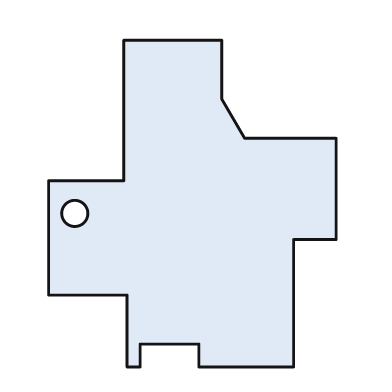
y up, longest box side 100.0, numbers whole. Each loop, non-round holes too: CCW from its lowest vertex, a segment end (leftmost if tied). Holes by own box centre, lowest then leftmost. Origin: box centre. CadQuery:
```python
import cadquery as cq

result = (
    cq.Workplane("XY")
    .moveTo(-20.0, -50.0)
    .lineTo(-16.0, -50.0)
    .lineTo(-16.0, -43.0)
    .lineTo(2.0, -43.0)
    .lineTo(2.0, -50.0)
    .lineTo(31.0, -50.0)
    .lineTo(31.0, -11.0)
    .lineTo(44.0, -11.0)
    .lineTo(44.0, 20.0)
    .lineTo(16.0, 20.0)
    .lineTo(9.0, 32.0)
    .lineTo(9.0, 50.0)
    .lineTo(-21.0, 50.0)
    .lineTo(-21.0, 7.0)
    .lineTo(-44.0, 7.0)
    .lineTo(-44.0, -28.0)
    .lineTo(-20.0, -28.0)
    .close()
    .moveTo(-36.0, -3.0)
    .circle(4.0)
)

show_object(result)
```